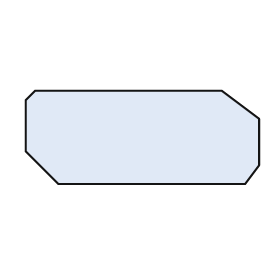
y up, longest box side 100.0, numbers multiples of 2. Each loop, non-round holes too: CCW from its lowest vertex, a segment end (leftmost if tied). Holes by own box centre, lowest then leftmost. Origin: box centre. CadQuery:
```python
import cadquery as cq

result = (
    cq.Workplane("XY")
    .moveTo(-36.0, -20.0)
    .lineTo(44.0, -20.0)
    .lineTo(50.0, -12.0)
    .lineTo(50.0, 8.0)
    .lineTo(34.0, 20.0)
    .lineTo(-46.0, 20.0)
    .lineTo(-50.0, 16.0)
    .lineTo(-50.0, -6.0)
    .close()
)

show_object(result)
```